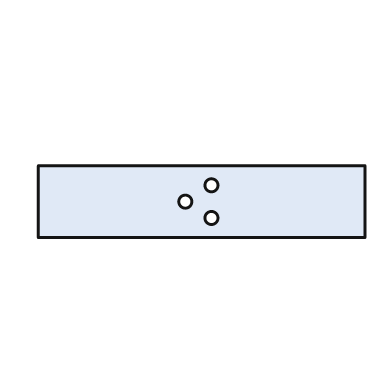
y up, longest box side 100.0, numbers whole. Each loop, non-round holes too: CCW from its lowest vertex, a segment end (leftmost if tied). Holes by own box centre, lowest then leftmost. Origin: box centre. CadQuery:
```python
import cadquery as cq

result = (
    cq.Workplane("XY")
    .moveTo(-50.0, -11.0)
    .lineTo(50.0, -11.0)
    .lineTo(50.0, 11.0)
    .lineTo(-50.0, 11.0)
    .close()
    .moveTo(3.0, -5.0)
    .circle(2.0)
    .moveTo(-5.0, 0.0)
    .circle(2.0)
    .moveTo(3.0, 5.0)
    .circle(2.0)
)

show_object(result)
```